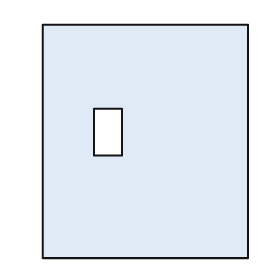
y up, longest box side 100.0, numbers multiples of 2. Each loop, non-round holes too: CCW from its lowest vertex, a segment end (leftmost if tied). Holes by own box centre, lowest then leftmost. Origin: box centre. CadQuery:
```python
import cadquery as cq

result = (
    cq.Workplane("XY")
    .moveTo(-44.0, -50.0)
    .lineTo(44.0, -50.0)
    .lineTo(44.0, 50.0)
    .lineTo(-44.0, 50.0)
    .close()
    .moveTo(-22.0, -6.0)
    .lineTo(-10.0, -6.0)
    .lineTo(-10.0, 14.0)
    .lineTo(-22.0, 14.0)
    .close()
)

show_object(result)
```